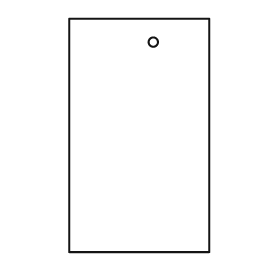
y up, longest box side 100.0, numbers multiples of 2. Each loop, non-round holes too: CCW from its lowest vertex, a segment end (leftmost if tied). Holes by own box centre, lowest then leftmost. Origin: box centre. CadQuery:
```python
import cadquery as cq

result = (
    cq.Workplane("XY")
    .moveTo(-30.0, -50.0)
    .lineTo(30.0, -50.0)
    .lineTo(30.0, 50.0)
    .lineTo(-30.0, 50.0)
    .close()
    .moveTo(6.0, 40.0)
    .circle(2.0)
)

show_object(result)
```